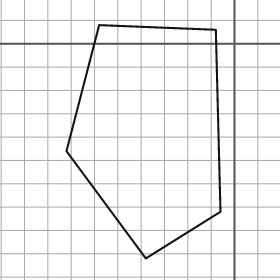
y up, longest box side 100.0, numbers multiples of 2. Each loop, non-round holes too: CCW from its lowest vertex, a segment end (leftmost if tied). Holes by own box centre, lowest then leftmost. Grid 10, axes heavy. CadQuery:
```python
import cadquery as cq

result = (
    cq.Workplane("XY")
    .moveTo(-38.0, -92.0)
    .lineTo(-6.0, -72.0)
    .lineTo(-8.0, 6.0)
    .lineTo(-58.0, 8.0)
    .lineTo(-72.0, -46.0)
    .close()
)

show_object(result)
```